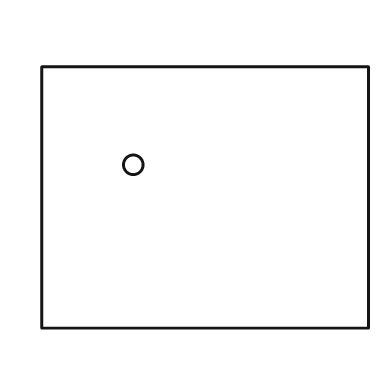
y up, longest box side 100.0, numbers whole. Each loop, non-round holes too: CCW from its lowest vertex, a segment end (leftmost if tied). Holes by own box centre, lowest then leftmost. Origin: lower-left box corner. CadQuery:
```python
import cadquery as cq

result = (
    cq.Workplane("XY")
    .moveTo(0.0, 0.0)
    .lineTo(100.0, 0.0)
    .lineTo(100.0, 80.0)
    .lineTo(0.0, 80.0)
    .close()
    .moveTo(28.0, 50.0)
    .circle(3.0)
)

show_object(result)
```